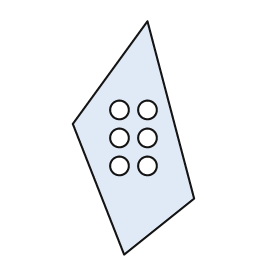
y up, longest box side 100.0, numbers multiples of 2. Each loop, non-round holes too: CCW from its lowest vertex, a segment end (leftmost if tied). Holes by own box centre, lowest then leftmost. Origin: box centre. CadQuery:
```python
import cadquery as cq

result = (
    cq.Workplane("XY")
    .moveTo(-4.0, -50.0)
    .lineTo(26.0, -26.0)
    .lineTo(6.0, 50.0)
    .lineTo(-26.0, 6.0)
    .close()
    .moveTo(-6.0, -12.0)
    .circle(4.0)
    .moveTo(6.0, -12.0)
    .circle(4.0)
    .moveTo(-6.0, 0.0)
    .circle(4.0)
    .moveTo(6.0, 0.0)
    .circle(4.0)
    .moveTo(-6.0, 12.0)
    .circle(4.0)
    .moveTo(6.0, 12.0)
    .circle(4.0)
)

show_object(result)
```